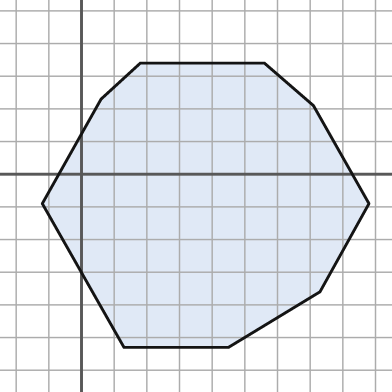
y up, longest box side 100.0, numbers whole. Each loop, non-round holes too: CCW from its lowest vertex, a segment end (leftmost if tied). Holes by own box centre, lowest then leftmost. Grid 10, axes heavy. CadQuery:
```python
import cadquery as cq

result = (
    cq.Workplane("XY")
    .moveTo(13.0, -53.0)
    .lineTo(45.0, -53.0)
    .lineTo(73.0, -36.0)
    .lineTo(88.0, -9.0)
    .lineTo(71.0, 21.0)
    .lineTo(56.0, 34.0)
    .lineTo(18.0, 34.0)
    .lineTo(6.0, 23.0)
    .lineTo(-12.0, -9.0)
    .close()
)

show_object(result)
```